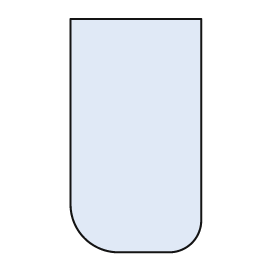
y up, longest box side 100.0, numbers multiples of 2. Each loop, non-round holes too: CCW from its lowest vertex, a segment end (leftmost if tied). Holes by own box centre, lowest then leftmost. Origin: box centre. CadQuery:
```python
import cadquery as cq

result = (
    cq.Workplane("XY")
    .moveTo(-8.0, -50.0)
    .lineTo(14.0, -50.0)
    .threePointArc((24.0, -46.0), (28.0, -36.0))
    .lineTo(28.0, 50.0)
    .lineTo(-28.0, 50.0)
    .lineTo(-28.0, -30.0)
    .threePointArc((-22.0, -44.0), (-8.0, -50.0))
    .close()
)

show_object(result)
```